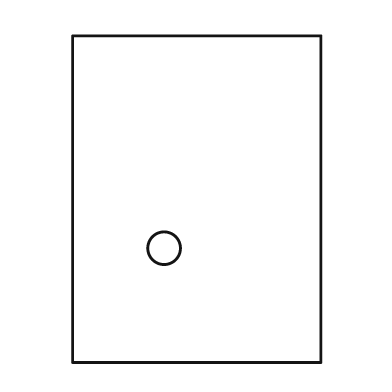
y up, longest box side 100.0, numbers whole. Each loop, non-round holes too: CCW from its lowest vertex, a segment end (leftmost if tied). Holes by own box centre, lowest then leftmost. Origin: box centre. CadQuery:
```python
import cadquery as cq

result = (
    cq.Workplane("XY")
    .moveTo(-38.0, -50.0)
    .lineTo(38.0, -50.0)
    .lineTo(38.0, 50.0)
    .lineTo(-38.0, 50.0)
    .close()
    .moveTo(-10.0, -15.0)
    .circle(5.0)
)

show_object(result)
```